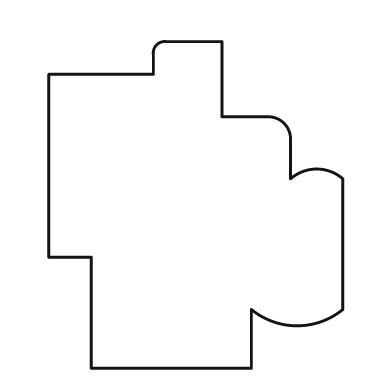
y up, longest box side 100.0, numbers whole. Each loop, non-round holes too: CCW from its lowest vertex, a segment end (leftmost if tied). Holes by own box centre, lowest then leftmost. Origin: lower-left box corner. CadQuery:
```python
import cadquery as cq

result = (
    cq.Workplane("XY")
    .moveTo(13.0, 0.0)
    .lineTo(62.0, 0.0)
    .lineTo(62.0, 18.0)
    .threePointArc((76.0, 13.0), (90.0, 18.0))
    .lineTo(90.0, 58.0)
    .threePointArc((82.0, 61.0), (74.0, 58.0))
    .lineTo(74.0, 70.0)
    .threePointArc((72.0, 75.0), (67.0, 77.0))
    .lineTo(53.0, 77.0)
    .lineTo(53.0, 100.0)
    .lineTo(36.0, 100.0)
    .threePointArc((33.0, 99.0), (32.0, 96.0))
    .lineTo(32.0, 90.0)
    .lineTo(0.0, 90.0)
    .lineTo(0.0, 34.0)
    .lineTo(13.0, 34.0)
    .close()
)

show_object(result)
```